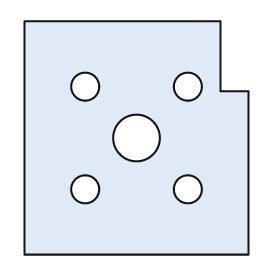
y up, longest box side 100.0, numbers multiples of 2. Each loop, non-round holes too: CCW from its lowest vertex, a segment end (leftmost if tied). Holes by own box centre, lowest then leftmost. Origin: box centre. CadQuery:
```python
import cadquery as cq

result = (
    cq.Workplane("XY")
    .moveTo(-48.0, -50.0)
    .lineTo(48.0, -50.0)
    .lineTo(48.0, 20.0)
    .lineTo(36.0, 20.0)
    .lineTo(36.0, 50.0)
    .lineTo(-48.0, 50.0)
    .close()
    .moveTo(-22.0, -22.0)
    .circle(6.0)
    .moveTo(22.0, -22.0)
    .circle(6.0)
    .moveTo(0.0, 0.0)
    .circle(10.0)
    .moveTo(-22.0, 22.0)
    .circle(6.0)
    .moveTo(22.0, 22.0)
    .circle(6.0)
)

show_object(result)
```